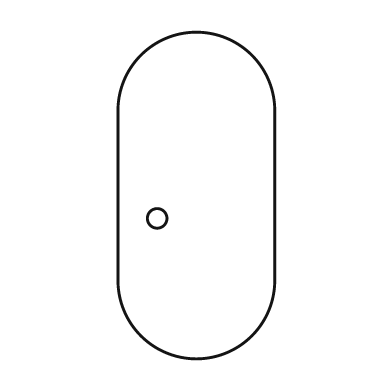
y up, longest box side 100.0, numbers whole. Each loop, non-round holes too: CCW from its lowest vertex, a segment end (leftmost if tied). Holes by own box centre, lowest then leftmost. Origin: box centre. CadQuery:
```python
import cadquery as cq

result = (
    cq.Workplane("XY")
    .moveTo(-24.0, -26.0)
    .threePointArc((0.0, -50.0), (24.0, -26.0))
    .lineTo(24.0, 26.0)
    .threePointArc((0.0, 50.0), (-24.0, 26.0))
    .close()
    .moveTo(-12.0, -7.0)
    .circle(3.0)
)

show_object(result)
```